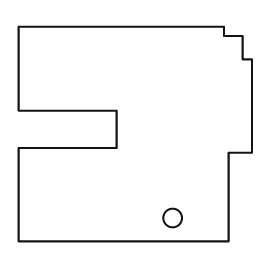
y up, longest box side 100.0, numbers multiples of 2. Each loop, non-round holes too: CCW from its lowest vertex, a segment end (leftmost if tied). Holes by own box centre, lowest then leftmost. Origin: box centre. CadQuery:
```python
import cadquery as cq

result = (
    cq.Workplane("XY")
    .moveTo(-50.0, -46.0)
    .lineTo(40.0, -46.0)
    .lineTo(40.0, -8.0)
    .lineTo(50.0, -8.0)
    .lineTo(50.0, 32.0)
    .lineTo(46.0, 32.0)
    .lineTo(46.0, 42.0)
    .lineTo(38.0, 42.0)
    .lineTo(38.0, 46.0)
    .lineTo(-50.0, 46.0)
    .lineTo(-50.0, 10.0)
    .lineTo(-8.0, 10.0)
    .lineTo(-8.0, -6.0)
    .lineTo(-50.0, -6.0)
    .close()
    .moveTo(16.0, -36.0)
    .circle(4.0)
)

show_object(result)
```